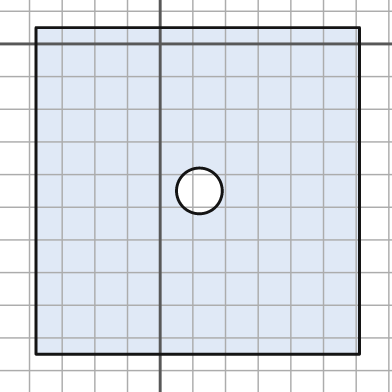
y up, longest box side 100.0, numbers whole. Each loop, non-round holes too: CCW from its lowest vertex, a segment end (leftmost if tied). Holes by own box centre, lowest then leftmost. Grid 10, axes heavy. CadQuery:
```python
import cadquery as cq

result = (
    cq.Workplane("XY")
    .moveTo(-38.0, -95.0)
    .lineTo(61.0, -95.0)
    .lineTo(61.0, 5.0)
    .lineTo(-38.0, 5.0)
    .close()
    .moveTo(12.0, -45.0)
    .circle(7.0)
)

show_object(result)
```